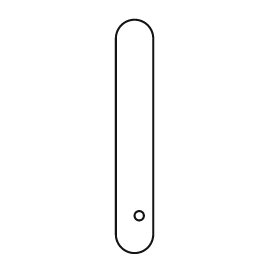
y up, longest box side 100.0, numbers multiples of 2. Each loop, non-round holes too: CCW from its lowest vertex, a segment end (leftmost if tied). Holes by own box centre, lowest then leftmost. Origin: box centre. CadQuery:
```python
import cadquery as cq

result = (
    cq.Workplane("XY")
    .moveTo(-8.0, -42.0)
    .threePointArc((0.0, -50.0), (8.0, -42.0))
    .lineTo(8.0, 42.0)
    .threePointArc((0.0, 50.0), (-8.0, 42.0))
    .close()
    .moveTo(2.0, -34.0)
    .circle(2.0)
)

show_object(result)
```